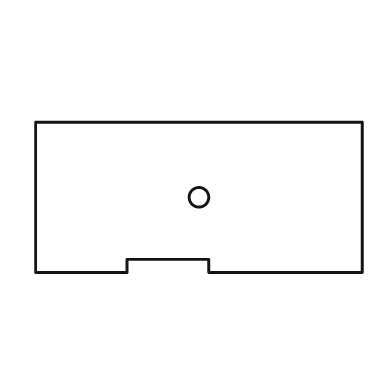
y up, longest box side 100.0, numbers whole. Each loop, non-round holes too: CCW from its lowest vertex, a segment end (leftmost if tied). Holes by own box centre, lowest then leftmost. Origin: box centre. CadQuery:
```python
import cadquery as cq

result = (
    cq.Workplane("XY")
    .moveTo(-50.0, -23.0)
    .lineTo(-22.0, -23.0)
    .lineTo(-22.0, -19.0)
    .lineTo(3.0, -19.0)
    .lineTo(3.0, -23.0)
    .lineTo(50.0, -23.0)
    .lineTo(50.0, 23.0)
    .lineTo(-50.0, 23.0)
    .close()
    .moveTo(0.0, 0.0)
    .circle(3.0)
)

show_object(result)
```